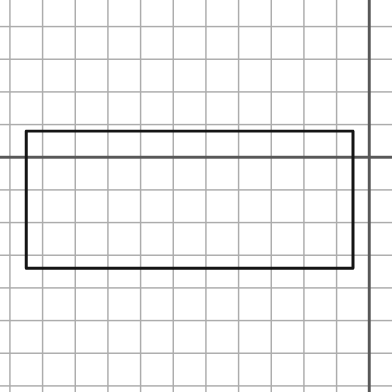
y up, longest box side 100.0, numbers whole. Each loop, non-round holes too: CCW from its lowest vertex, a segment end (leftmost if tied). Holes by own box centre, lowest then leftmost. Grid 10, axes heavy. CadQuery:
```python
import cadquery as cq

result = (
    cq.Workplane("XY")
    .moveTo(-105.0, -34.0)
    .lineTo(-5.0, -34.0)
    .lineTo(-5.0, 8.0)
    .lineTo(-105.0, 8.0)
    .close()
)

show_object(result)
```